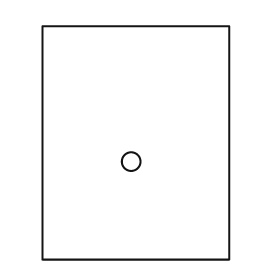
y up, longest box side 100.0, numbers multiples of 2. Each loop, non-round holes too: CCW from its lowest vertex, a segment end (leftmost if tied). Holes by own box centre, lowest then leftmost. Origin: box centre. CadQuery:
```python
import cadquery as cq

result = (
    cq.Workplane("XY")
    .moveTo(-40.0, -50.0)
    .lineTo(40.0, -50.0)
    .lineTo(40.0, 50.0)
    .lineTo(-40.0, 50.0)
    .close()
    .moveTo(-2.0, -8.0)
    .circle(4.0)
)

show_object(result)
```